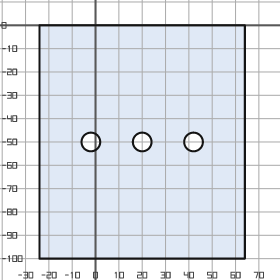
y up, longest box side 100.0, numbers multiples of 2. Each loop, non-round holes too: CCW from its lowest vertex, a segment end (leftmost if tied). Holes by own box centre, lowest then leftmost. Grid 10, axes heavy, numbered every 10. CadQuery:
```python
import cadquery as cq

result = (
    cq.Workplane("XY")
    .moveTo(-24.0, -100.0)
    .lineTo(64.0, -100.0)
    .lineTo(64.0, 0.0)
    .lineTo(-24.0, 0.0)
    .close()
    .moveTo(-2.0, -50.0)
    .circle(4.0)
    .moveTo(20.0, -50.0)
    .circle(4.0)
    .moveTo(42.0, -50.0)
    .circle(4.0)
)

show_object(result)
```